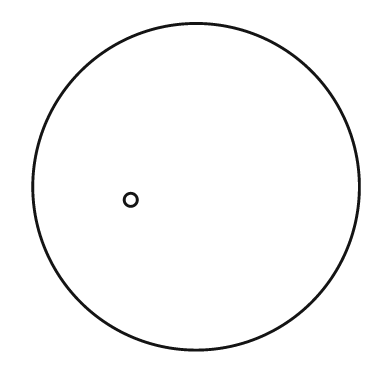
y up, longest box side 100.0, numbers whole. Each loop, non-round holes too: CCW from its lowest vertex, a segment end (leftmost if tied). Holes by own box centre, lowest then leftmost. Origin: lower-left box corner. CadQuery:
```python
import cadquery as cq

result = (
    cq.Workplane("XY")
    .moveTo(50.0, 50.0)
    .circle(50.0)
    .moveTo(30.0, 46.0)
    .circle(2.0)
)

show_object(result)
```